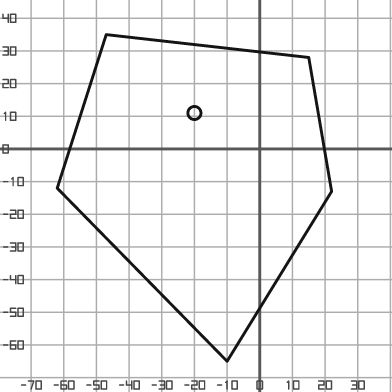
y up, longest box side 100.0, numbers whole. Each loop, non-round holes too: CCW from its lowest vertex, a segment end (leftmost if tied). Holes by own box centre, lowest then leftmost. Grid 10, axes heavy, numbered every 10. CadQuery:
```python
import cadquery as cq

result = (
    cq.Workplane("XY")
    .moveTo(-10.0, -65.0)
    .lineTo(22.0, -13.0)
    .lineTo(15.0, 28.0)
    .lineTo(-47.0, 35.0)
    .lineTo(-62.0, -12.0)
    .close()
    .moveTo(-20.0, 11.0)
    .circle(2.0)
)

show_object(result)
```